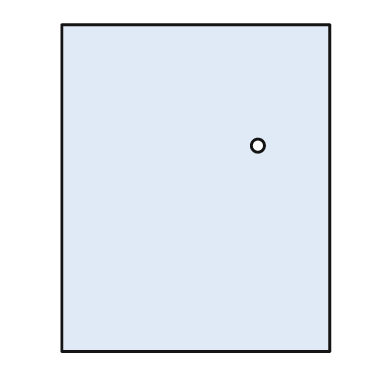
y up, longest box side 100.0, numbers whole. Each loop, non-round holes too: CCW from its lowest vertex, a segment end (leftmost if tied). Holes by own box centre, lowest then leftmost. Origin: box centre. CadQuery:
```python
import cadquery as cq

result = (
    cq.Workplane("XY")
    .moveTo(-41.0, -50.0)
    .lineTo(41.0, -50.0)
    .lineTo(41.0, 50.0)
    .lineTo(-41.0, 50.0)
    .close()
    .moveTo(19.0, 13.0)
    .circle(2.0)
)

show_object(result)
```